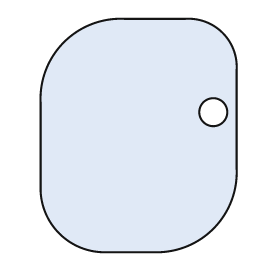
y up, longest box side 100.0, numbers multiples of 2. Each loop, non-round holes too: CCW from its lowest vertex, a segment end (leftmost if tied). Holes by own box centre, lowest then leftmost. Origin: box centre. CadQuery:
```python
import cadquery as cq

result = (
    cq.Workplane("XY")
    .moveTo(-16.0, -50.0)
    .lineTo(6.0, -50.0)
    .threePointArc((32.0, -40.0), (42.0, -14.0))
    .lineTo(42.0, 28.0)
    .threePointArc((36.0, 44.0), (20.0, 50.0))
    .lineTo(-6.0, 50.0)
    .threePointArc((-32.0, 40.0), (-42.0, 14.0))
    .lineTo(-42.0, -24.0)
    .threePointArc((-34.0, -42.0), (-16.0, -50.0))
    .close()
    .moveTo(32.0, 10.0)
    .circle(6.0)
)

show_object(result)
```